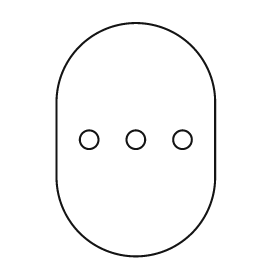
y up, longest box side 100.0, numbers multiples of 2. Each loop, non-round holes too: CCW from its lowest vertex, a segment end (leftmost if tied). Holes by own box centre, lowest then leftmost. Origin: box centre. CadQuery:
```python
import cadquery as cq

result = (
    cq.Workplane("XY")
    .moveTo(-34.0, -16.0)
    .threePointArc((0.0, -50.0), (34.0, -16.0))
    .lineTo(34.0, 16.0)
    .threePointArc((0.0, 50.0), (-34.0, 16.0))
    .close()
    .moveTo(-20.0, 0.0)
    .circle(4.0)
    .moveTo(0.0, 0.0)
    .circle(4.0)
    .moveTo(20.0, 0.0)
    .circle(4.0)
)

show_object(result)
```